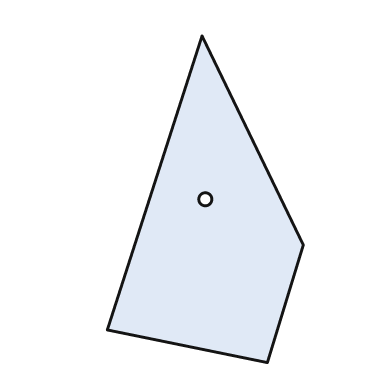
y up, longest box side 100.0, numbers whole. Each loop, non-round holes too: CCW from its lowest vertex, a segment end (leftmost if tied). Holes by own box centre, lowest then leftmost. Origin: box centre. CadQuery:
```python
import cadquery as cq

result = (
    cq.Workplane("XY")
    .moveTo(19.0, -50.0)
    .lineTo(30.0, -14.0)
    .lineTo(-1.0, 50.0)
    .lineTo(-30.0, -40.0)
    .close()
    .moveTo(0.0, 0.0)
    .circle(2.0)
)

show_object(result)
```